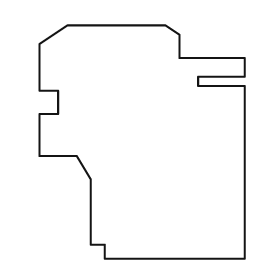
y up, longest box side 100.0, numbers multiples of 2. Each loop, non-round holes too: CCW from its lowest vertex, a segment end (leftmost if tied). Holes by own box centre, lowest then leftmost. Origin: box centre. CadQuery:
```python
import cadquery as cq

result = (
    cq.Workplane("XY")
    .moveTo(-16.0, -50.0)
    .lineTo(44.0, -50.0)
    .lineTo(44.0, 24.0)
    .lineTo(24.0, 24.0)
    .lineTo(24.0, 28.0)
    .lineTo(44.0, 28.0)
    .lineTo(44.0, 36.0)
    .lineTo(16.0, 36.0)
    .lineTo(16.0, 46.0)
    .lineTo(10.0, 50.0)
    .lineTo(-32.0, 50.0)
    .lineTo(-44.0, 42.0)
    .lineTo(-44.0, 22.0)
    .lineTo(-36.0, 22.0)
    .lineTo(-36.0, 12.0)
    .lineTo(-44.0, 12.0)
    .lineTo(-44.0, -6.0)
    .lineTo(-28.0, -6.0)
    .lineTo(-22.0, -16.0)
    .lineTo(-22.0, -44.0)
    .lineTo(-16.0, -44.0)
    .close()
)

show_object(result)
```